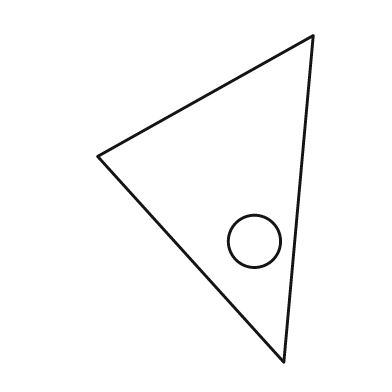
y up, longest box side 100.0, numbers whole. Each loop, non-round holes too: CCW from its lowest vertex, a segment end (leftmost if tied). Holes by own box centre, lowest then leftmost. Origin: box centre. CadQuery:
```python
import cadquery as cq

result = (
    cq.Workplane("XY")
    .moveTo(24.0, -50.0)
    .lineTo(33.0, 50.0)
    .lineTo(-33.0, 13.0)
    .close()
    .moveTo(15.0, -13.0)
    .circle(8.0)
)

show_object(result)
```